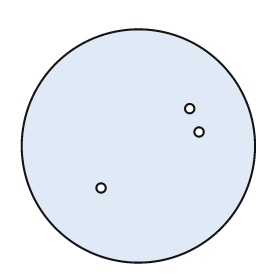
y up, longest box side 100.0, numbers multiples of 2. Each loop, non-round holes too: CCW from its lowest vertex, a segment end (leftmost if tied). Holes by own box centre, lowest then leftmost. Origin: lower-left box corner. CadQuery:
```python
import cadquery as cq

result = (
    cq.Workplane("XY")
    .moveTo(50.0, 50.0)
    .circle(50.0)
    .moveTo(34.0, 32.0)
    .circle(2.0)
    .moveTo(76.0, 56.0)
    .circle(2.0)
    .moveTo(72.0, 66.0)
    .circle(2.0)
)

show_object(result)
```